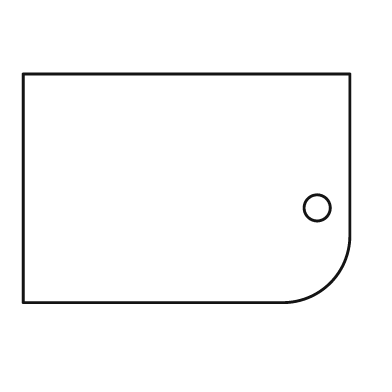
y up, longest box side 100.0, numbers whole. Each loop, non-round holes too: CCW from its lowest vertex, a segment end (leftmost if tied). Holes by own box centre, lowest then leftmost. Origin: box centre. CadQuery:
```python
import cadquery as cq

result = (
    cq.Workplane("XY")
    .moveTo(-50.0, -35.0)
    .lineTo(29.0, -35.0)
    .threePointArc((44.0, -29.0), (50.0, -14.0))
    .lineTo(50.0, 35.0)
    .lineTo(-50.0, 35.0)
    .close()
    .moveTo(40.0, -6.0)
    .circle(4.0)
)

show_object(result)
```